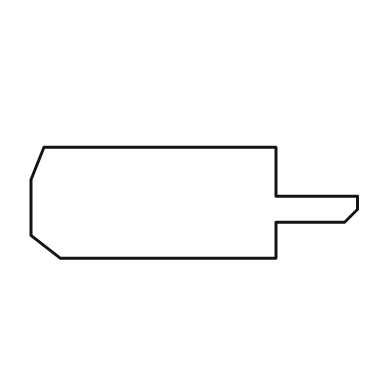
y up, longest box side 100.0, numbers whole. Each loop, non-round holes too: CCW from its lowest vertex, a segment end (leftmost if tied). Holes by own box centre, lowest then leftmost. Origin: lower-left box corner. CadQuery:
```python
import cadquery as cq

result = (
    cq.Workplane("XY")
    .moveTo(9.0, 0.0)
    .lineTo(75.0, 0.0)
    .lineTo(75.0, 11.0)
    .lineTo(96.0, 11.0)
    .lineTo(100.0, 15.0)
    .lineTo(100.0, 19.0)
    .lineTo(75.0, 19.0)
    .lineTo(75.0, 34.0)
    .lineTo(4.0, 34.0)
    .lineTo(0.0, 24.0)
    .lineTo(0.0, 7.0)
    .close()
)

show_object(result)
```